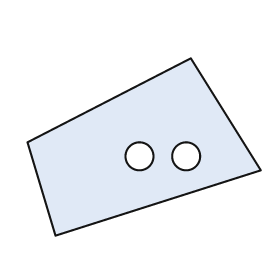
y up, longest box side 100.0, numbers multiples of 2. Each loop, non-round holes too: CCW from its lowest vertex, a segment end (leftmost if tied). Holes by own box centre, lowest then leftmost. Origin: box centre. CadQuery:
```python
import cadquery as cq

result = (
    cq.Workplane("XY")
    .moveTo(-38.0, -38.0)
    .lineTo(50.0, -10.0)
    .lineTo(20.0, 38.0)
    .lineTo(-50.0, 2.0)
    .close()
    .moveTo(-2.0, -4.0)
    .circle(6.0)
    .moveTo(18.0, -4.0)
    .circle(6.0)
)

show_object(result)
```